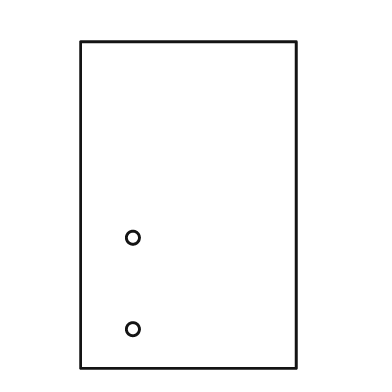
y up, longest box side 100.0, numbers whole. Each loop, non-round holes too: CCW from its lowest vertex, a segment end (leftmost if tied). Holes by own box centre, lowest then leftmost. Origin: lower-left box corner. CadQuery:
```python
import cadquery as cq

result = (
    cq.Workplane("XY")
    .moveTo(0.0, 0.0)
    .lineTo(66.0, 0.0)
    .lineTo(66.0, 100.0)
    .lineTo(0.0, 100.0)
    .close()
    .moveTo(16.0, 12.0)
    .circle(2.0)
    .moveTo(16.0, 40.0)
    .circle(2.0)
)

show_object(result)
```